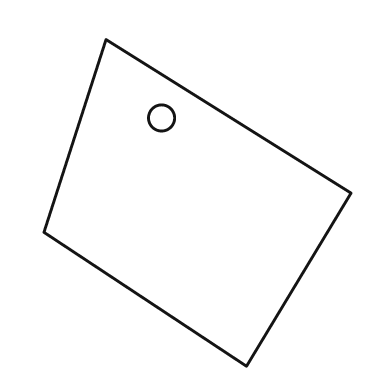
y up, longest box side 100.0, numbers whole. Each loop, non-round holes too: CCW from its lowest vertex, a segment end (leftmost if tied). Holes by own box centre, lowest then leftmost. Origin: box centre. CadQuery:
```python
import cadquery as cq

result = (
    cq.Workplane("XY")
    .moveTo(15.0, -50.0)
    .lineTo(47.0, 3.0)
    .lineTo(-28.0, 50.0)
    .lineTo(-47.0, -9.0)
    .close()
    .moveTo(-11.0, 26.0)
    .circle(4.0)
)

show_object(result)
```